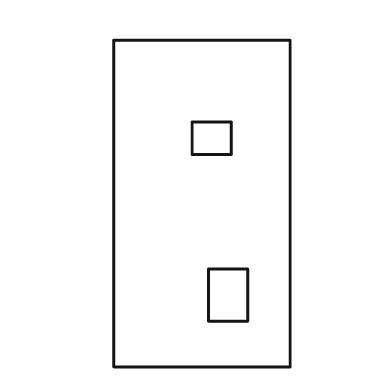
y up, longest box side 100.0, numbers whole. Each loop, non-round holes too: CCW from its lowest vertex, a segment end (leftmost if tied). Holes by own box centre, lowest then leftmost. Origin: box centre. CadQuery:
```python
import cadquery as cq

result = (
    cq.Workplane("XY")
    .moveTo(-27.0, -50.0)
    .lineTo(27.0, -50.0)
    .lineTo(27.0, 50.0)
    .lineTo(-27.0, 50.0)
    .close()
    .moveTo(2.0, -36.0)
    .lineTo(14.0, -36.0)
    .lineTo(14.0, -20.0)
    .lineTo(2.0, -20.0)
    .close()
    .moveTo(-3.0, 15.0)
    .lineTo(9.0, 15.0)
    .lineTo(9.0, 25.0)
    .lineTo(-3.0, 25.0)
    .close()
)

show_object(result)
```